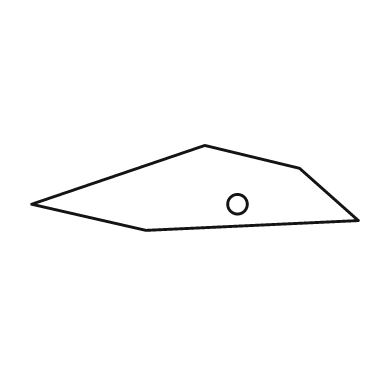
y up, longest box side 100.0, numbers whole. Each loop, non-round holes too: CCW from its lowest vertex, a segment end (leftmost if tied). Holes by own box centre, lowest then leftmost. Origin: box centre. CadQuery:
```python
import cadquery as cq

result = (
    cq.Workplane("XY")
    .moveTo(-15.0, -13.0)
    .lineTo(50.0, -10.0)
    .lineTo(32.0, 6.0)
    .lineTo(3.0, 13.0)
    .lineTo(-50.0, -5.0)
    .close()
    .moveTo(13.0, -5.0)
    .circle(3.0)
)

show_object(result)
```